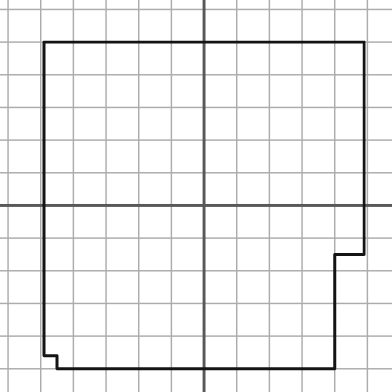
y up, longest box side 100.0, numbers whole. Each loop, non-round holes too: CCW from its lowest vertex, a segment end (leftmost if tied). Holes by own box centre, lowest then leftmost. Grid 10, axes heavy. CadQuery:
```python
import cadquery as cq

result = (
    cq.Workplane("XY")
    .moveTo(-45.0, -50.0)
    .lineTo(40.0, -50.0)
    .lineTo(40.0, -15.0)
    .lineTo(49.0, -15.0)
    .lineTo(49.0, 50.0)
    .lineTo(-49.0, 50.0)
    .lineTo(-49.0, -46.0)
    .lineTo(-45.0, -46.0)
    .close()
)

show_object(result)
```